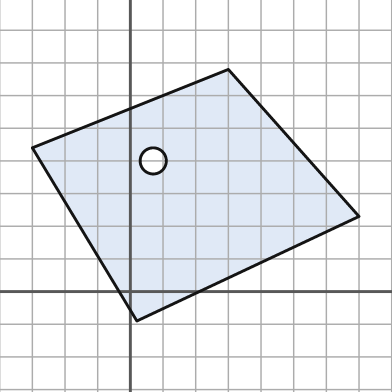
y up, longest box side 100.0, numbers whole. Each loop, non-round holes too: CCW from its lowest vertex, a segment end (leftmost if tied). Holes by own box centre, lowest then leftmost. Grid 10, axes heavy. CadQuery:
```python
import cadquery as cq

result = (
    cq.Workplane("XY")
    .moveTo(2.0, -9.0)
    .lineTo(70.0, 23.0)
    .lineTo(30.0, 68.0)
    .lineTo(-30.0, 44.0)
    .close()
    .moveTo(7.0, 40.0)
    .circle(4.0)
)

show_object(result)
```